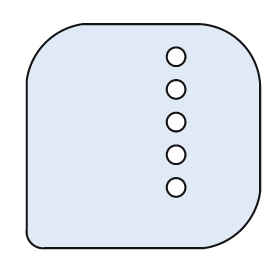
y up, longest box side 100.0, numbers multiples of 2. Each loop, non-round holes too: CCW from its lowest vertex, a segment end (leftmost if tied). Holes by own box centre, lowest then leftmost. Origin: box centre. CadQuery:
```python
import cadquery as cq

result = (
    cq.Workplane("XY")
    .moveTo(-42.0, -48.0)
    .lineTo(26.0, -48.0)
    .threePointArc((42.0, -40.0), (50.0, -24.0))
    .lineTo(50.0, 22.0)
    .threePointArc((42.0, 40.0), (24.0, 48.0))
    .lineTo(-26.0, 48.0)
    .threePointArc((-42.0, 40.0), (-50.0, 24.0))
    .lineTo(-50.0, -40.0)
    .threePointArc((-48.0, -46.0), (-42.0, -48.0))
    .close()
    .moveTo(14.0, -22.0)
    .circle(4.0)
    .moveTo(14.0, -8.0)
    .circle(4.0)
    .moveTo(14.0, 6.0)
    .circle(4.0)
    .moveTo(14.0, 20.0)
    .circle(4.0)
    .moveTo(14.0, 34.0)
    .circle(4.0)
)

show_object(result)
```